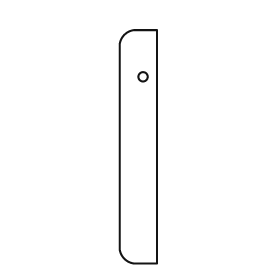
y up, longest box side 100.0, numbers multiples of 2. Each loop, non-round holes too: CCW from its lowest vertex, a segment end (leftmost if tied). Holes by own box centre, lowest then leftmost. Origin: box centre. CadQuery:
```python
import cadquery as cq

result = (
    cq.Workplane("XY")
    .moveTo(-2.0, -50.0)
    .lineTo(8.0, -50.0)
    .lineTo(8.0, 50.0)
    .lineTo(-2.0, 50.0)
    .threePointArc((-6.0, 48.0), (-8.0, 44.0))
    .lineTo(-8.0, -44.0)
    .threePointArc((-6.0, -48.0), (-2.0, -50.0))
    .close()
    .moveTo(2.0, 30.0)
    .circle(2.0)
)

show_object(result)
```